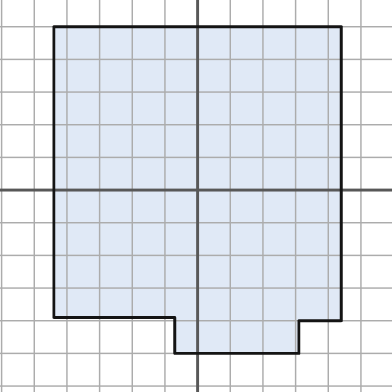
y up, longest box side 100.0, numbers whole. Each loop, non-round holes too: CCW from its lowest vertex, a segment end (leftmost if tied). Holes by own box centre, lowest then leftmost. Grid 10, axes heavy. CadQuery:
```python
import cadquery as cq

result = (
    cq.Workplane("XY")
    .moveTo(-7.0, -50.0)
    .lineTo(31.0, -50.0)
    .lineTo(31.0, -40.0)
    .lineTo(44.0, -40.0)
    .lineTo(44.0, 50.0)
    .lineTo(-44.0, 50.0)
    .lineTo(-44.0, -39.0)
    .lineTo(-7.0, -39.0)
    .close()
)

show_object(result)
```